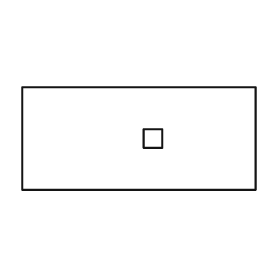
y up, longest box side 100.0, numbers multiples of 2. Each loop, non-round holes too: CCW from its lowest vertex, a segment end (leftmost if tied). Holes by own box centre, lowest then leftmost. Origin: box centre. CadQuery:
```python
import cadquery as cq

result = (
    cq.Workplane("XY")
    .moveTo(-50.0, -22.0)
    .lineTo(50.0, -22.0)
    .lineTo(50.0, 22.0)
    .lineTo(-50.0, 22.0)
    .close()
    .moveTo(2.0, -4.0)
    .lineTo(10.0, -4.0)
    .lineTo(10.0, 4.0)
    .lineTo(2.0, 4.0)
    .close()
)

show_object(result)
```